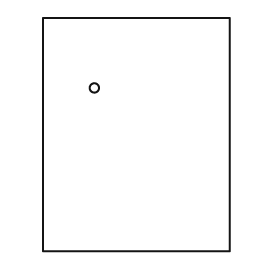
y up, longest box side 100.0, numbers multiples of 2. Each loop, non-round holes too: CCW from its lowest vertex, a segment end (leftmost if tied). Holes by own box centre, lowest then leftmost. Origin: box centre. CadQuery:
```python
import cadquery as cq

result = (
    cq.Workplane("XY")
    .moveTo(-40.0, -50.0)
    .lineTo(40.0, -50.0)
    .lineTo(40.0, 50.0)
    .lineTo(-40.0, 50.0)
    .close()
    .moveTo(-18.0, 20.0)
    .circle(2.0)
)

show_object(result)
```